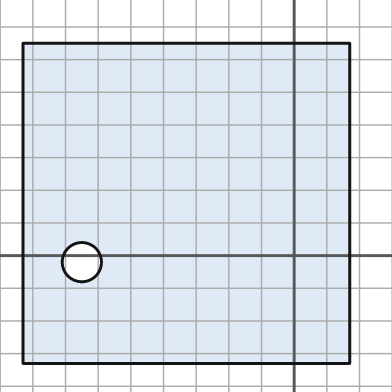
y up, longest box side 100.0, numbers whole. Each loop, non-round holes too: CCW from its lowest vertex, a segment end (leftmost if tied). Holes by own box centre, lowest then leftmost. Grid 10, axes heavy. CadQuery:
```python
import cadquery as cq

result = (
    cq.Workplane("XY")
    .moveTo(-83.0, -33.0)
    .lineTo(17.0, -33.0)
    .lineTo(17.0, 65.0)
    .lineTo(-83.0, 65.0)
    .close()
    .moveTo(-65.0, -2.0)
    .circle(6.0)
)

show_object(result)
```